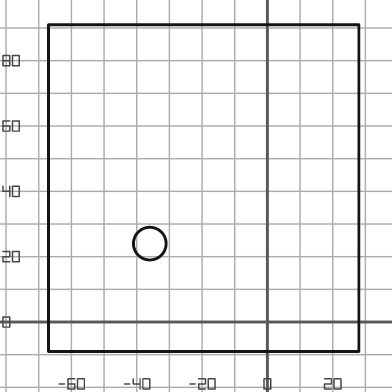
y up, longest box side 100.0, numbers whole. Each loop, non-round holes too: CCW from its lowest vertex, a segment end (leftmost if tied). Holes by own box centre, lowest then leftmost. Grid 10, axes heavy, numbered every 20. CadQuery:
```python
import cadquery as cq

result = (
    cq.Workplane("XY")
    .moveTo(-67.0, -9.0)
    .lineTo(28.0, -9.0)
    .lineTo(28.0, 91.0)
    .lineTo(-67.0, 91.0)
    .close()
    .moveTo(-36.0, 24.0)
    .circle(5.0)
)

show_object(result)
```